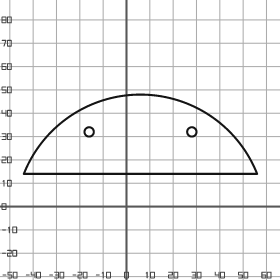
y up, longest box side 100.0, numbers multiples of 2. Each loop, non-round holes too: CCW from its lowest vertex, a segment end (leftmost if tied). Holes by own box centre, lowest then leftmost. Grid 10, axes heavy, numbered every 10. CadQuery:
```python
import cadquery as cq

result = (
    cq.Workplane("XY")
    .moveTo(-44.0, 14.0)
    .lineTo(56.0, 14.0)
    .threePointArc((6.0, 48.0), (-44.0, 14.0))
    .close()
    .moveTo(-16.0, 32.0)
    .circle(2.0)
    .moveTo(28.0, 32.0)
    .circle(2.0)
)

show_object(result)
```